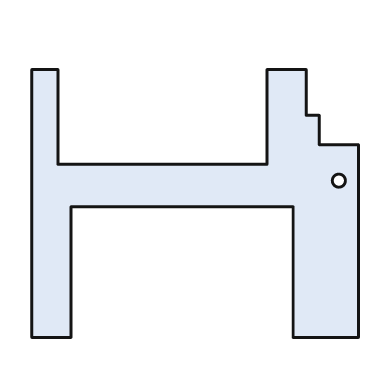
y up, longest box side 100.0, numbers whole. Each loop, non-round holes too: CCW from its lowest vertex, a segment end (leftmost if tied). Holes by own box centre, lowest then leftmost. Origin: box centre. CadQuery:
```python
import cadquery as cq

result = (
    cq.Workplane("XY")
    .moveTo(-50.0, -41.0)
    .lineTo(-38.0, -41.0)
    .lineTo(-38.0, -1.0)
    .lineTo(30.0, -1.0)
    .lineTo(30.0, -41.0)
    .lineTo(50.0, -41.0)
    .lineTo(50.0, 18.0)
    .lineTo(38.0, 18.0)
    .lineTo(38.0, 27.0)
    .lineTo(34.0, 27.0)
    .lineTo(34.0, 41.0)
    .lineTo(22.0, 41.0)
    .lineTo(22.0, 12.0)
    .lineTo(-42.0, 12.0)
    .lineTo(-42.0, 41.0)
    .lineTo(-50.0, 41.0)
    .close()
    .moveTo(44.0, 7.0)
    .circle(2.0)
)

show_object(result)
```